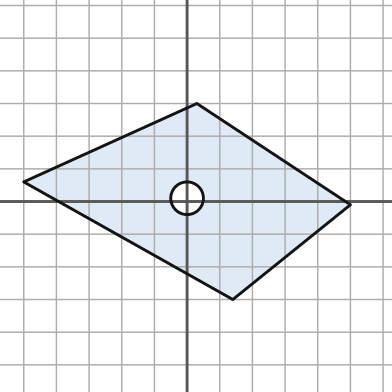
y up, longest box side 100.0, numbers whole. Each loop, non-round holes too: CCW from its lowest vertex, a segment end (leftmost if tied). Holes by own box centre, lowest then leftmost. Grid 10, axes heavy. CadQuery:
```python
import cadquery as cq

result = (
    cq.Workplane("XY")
    .moveTo(14.0, -30.0)
    .lineTo(50.0, -1.0)
    .lineTo(3.0, 30.0)
    .lineTo(-50.0, 6.0)
    .close()
    .moveTo(0.0, 1.0)
    .circle(5.0)
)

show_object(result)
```